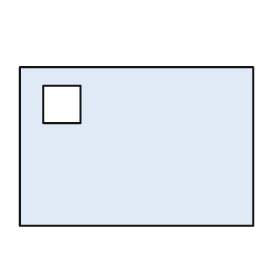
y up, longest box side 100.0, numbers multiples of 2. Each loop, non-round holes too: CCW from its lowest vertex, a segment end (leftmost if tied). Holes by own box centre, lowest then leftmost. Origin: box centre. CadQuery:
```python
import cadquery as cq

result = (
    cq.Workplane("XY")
    .moveTo(-50.0, -34.0)
    .lineTo(50.0, -34.0)
    .lineTo(50.0, 34.0)
    .lineTo(-50.0, 34.0)
    .close()
    .moveTo(-40.0, 10.0)
    .lineTo(-24.0, 10.0)
    .lineTo(-24.0, 26.0)
    .lineTo(-40.0, 26.0)
    .close()
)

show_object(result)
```